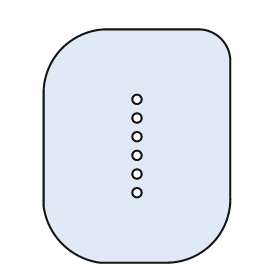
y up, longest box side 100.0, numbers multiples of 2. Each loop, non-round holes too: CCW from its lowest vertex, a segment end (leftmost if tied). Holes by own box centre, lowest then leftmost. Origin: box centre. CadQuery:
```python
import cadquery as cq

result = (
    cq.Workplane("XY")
    .moveTo(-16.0, -50.0)
    .lineTo(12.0, -50.0)
    .threePointArc((32.0, -42.0), (40.0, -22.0))
    .lineTo(40.0, 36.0)
    .threePointArc((36.0, 46.0), (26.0, 50.0))
    .lineTo(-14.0, 50.0)
    .threePointArc((-32.0, 42.0), (-40.0, 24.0))
    .lineTo(-40.0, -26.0)
    .threePointArc((-32.0, -42.0), (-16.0, -50.0))
    .close()
    .moveTo(0.0, -20.0)
    .circle(2.0)
    .moveTo(0.0, -12.0)
    .circle(2.0)
    .moveTo(0.0, -4.0)
    .circle(2.0)
    .moveTo(0.0, 4.0)
    .circle(2.0)
    .moveTo(0.0, 12.0)
    .circle(2.0)
    .moveTo(0.0, 20.0)
    .circle(2.0)
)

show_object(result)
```